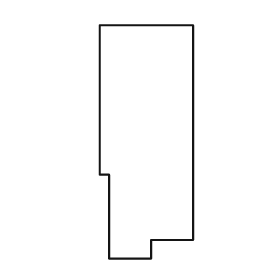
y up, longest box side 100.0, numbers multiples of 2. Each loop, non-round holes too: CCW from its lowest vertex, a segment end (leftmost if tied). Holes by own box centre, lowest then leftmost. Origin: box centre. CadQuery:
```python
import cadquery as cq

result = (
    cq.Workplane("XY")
    .moveTo(-16.0, -50.0)
    .lineTo(2.0, -50.0)
    .lineTo(2.0, -42.0)
    .lineTo(20.0, -42.0)
    .lineTo(20.0, 50.0)
    .lineTo(-20.0, 50.0)
    .lineTo(-20.0, -14.0)
    .lineTo(-16.0, -14.0)
    .close()
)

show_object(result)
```